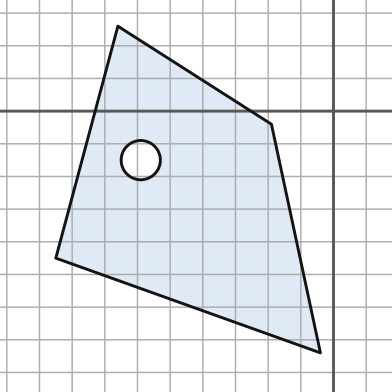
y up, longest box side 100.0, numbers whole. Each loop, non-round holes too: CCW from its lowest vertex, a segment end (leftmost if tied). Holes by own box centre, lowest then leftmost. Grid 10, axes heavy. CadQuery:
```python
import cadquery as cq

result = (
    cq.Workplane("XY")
    .moveTo(-4.0, -74.0)
    .lineTo(-19.0, -4.0)
    .lineTo(-66.0, 26.0)
    .lineTo(-85.0, -45.0)
    .close()
    .moveTo(-59.0, -15.0)
    .circle(6.0)
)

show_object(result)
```